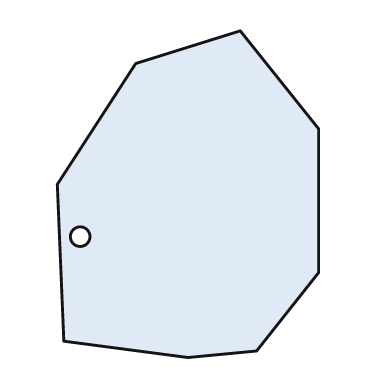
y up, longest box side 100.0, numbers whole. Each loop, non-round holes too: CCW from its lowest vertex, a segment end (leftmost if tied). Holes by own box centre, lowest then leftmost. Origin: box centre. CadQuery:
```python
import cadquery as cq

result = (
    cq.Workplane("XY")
    .moveTo(0.0, -50.0)
    .lineTo(21.0, -48.0)
    .lineTo(40.0, -24.0)
    .lineTo(40.0, 20.0)
    .lineTo(16.0, 50.0)
    .lineTo(-16.0, 40.0)
    .lineTo(-40.0, 3.0)
    .lineTo(-38.0, -45.0)
    .close()
    .moveTo(-33.0, -13.0)
    .circle(3.0)
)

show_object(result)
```